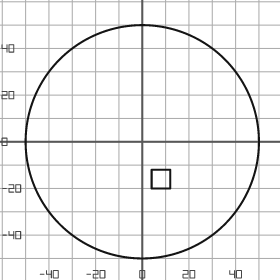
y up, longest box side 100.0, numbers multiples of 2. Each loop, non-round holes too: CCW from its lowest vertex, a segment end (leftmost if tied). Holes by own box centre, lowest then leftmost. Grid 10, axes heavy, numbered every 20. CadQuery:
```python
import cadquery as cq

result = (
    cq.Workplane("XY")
    .moveTo(0.0, 0.0)
    .circle(50.0)
    .moveTo(4.0, -20.0)
    .lineTo(12.0, -20.0)
    .lineTo(12.0, -12.0)
    .lineTo(4.0, -12.0)
    .close()
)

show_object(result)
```